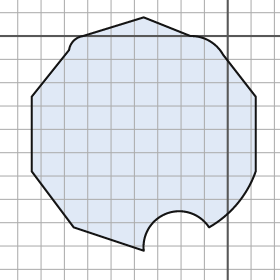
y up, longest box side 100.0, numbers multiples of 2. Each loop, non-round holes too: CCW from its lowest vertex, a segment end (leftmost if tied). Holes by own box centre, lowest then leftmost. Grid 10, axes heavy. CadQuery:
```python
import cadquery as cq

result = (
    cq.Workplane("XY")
    .moveTo(-36.0, -92.0)
    .threePointArc((-26.0, -76.0), (-8.0, -82.0))
    .threePointArc((4.0, -72.0), (12.0, -58.0))
    .lineTo(12.0, -26.0)
    .lineTo(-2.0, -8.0)
    .threePointArc((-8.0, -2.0), (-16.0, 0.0))
    .lineTo(-36.0, 8.0)
    .lineTo(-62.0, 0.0)
    .threePointArc((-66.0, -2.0), (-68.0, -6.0))
    .lineTo(-84.0, -26.0)
    .lineTo(-84.0, -58.0)
    .lineTo(-66.0, -82.0)
    .close()
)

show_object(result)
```